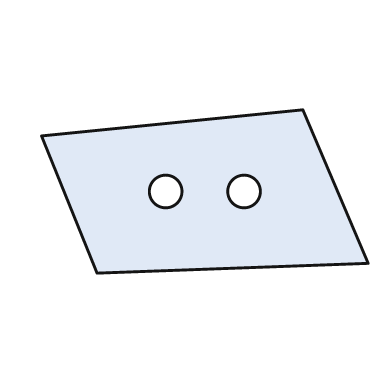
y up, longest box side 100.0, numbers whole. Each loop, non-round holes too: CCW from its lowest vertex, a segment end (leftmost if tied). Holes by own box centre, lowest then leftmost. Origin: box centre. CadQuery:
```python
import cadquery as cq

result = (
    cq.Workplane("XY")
    .moveTo(-33.0, -25.0)
    .lineTo(50.0, -22.0)
    .lineTo(30.0, 25.0)
    .lineTo(-50.0, 17.0)
    .close()
    .moveTo(-12.0, 0.0)
    .circle(5.0)
    .moveTo(12.0, 0.0)
    .circle(5.0)
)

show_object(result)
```